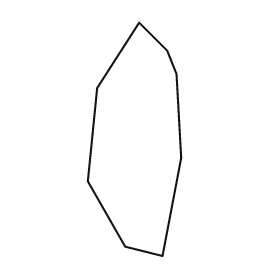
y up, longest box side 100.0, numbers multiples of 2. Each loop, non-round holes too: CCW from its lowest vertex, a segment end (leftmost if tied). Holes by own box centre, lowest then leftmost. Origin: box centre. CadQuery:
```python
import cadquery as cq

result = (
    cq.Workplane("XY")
    .moveTo(12.0, -50.0)
    .lineTo(20.0, -8.0)
    .lineTo(18.0, 28.0)
    .lineTo(14.0, 38.0)
    .lineTo(2.0, 50.0)
    .lineTo(-16.0, 22.0)
    .lineTo(-20.0, -18.0)
    .lineTo(-4.0, -46.0)
    .close()
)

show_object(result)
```